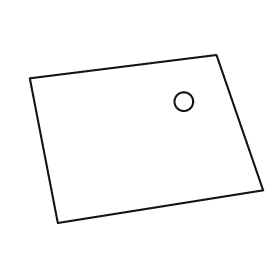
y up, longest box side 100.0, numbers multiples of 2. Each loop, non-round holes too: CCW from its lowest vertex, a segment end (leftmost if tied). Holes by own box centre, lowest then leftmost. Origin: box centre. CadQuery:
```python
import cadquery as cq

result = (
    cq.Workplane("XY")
    .moveTo(-38.0, -36.0)
    .lineTo(50.0, -22.0)
    .lineTo(30.0, 36.0)
    .lineTo(-50.0, 26.0)
    .close()
    .moveTo(16.0, 16.0)
    .circle(4.0)
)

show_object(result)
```